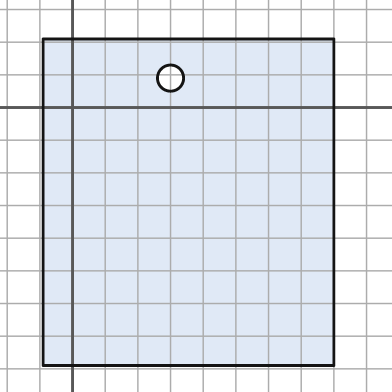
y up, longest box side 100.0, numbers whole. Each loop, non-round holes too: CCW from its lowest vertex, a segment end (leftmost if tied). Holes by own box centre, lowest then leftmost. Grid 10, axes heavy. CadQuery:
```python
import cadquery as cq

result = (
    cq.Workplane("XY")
    .moveTo(-9.0, -79.0)
    .lineTo(80.0, -79.0)
    .lineTo(80.0, 21.0)
    .lineTo(-9.0, 21.0)
    .close()
    .moveTo(30.0, 9.0)
    .circle(4.0)
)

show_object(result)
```